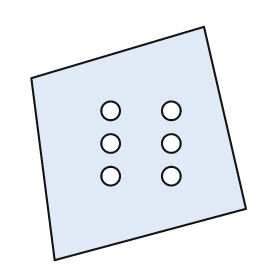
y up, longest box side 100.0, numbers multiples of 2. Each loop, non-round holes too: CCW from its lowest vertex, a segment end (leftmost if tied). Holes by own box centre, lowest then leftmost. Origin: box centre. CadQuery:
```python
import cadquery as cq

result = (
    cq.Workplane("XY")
    .moveTo(-36.0, -50.0)
    .lineTo(46.0, -28.0)
    .lineTo(28.0, 50.0)
    .lineTo(-46.0, 28.0)
    .close()
    .moveTo(-12.0, -14.0)
    .circle(4.0)
    .moveTo(14.0, -14.0)
    .circle(4.0)
    .moveTo(-12.0, 0.0)
    .circle(4.0)
    .moveTo(14.0, 0.0)
    .circle(4.0)
    .moveTo(-12.0, 14.0)
    .circle(4.0)
    .moveTo(14.0, 14.0)
    .circle(4.0)
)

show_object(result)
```